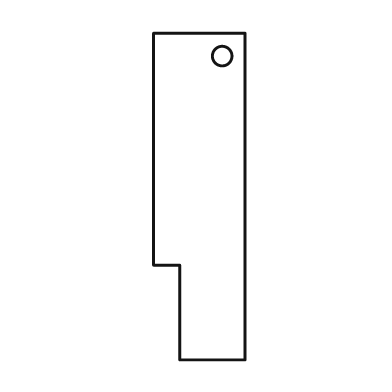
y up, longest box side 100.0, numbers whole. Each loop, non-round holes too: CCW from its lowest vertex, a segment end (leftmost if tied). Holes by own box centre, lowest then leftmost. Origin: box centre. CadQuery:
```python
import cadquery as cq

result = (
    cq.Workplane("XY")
    .moveTo(-6.0, -50.0)
    .lineTo(14.0, -50.0)
    .lineTo(14.0, 50.0)
    .lineTo(-14.0, 50.0)
    .lineTo(-14.0, -21.0)
    .lineTo(-6.0, -21.0)
    .close()
    .moveTo(7.0, 43.0)
    .circle(3.0)
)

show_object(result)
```